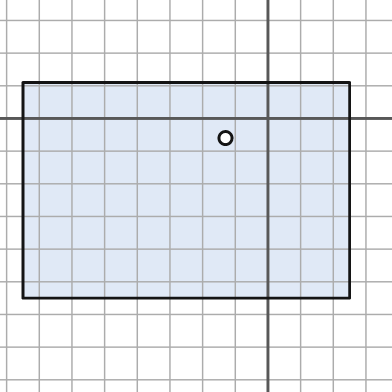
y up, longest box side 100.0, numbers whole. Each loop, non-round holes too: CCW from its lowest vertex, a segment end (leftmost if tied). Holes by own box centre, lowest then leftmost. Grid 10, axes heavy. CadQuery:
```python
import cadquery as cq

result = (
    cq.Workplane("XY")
    .moveTo(-75.0, -55.0)
    .lineTo(25.0, -55.0)
    .lineTo(25.0, 11.0)
    .lineTo(-75.0, 11.0)
    .close()
    .moveTo(-13.0, -6.0)
    .circle(2.0)
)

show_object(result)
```